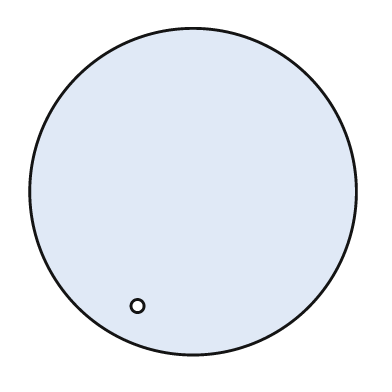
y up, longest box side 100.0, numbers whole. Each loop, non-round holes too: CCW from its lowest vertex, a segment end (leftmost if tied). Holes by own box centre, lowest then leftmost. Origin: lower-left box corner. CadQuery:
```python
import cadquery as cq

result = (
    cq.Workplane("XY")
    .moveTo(50.0, 50.0)
    .circle(50.0)
    .moveTo(33.0, 15.0)
    .circle(2.0)
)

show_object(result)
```